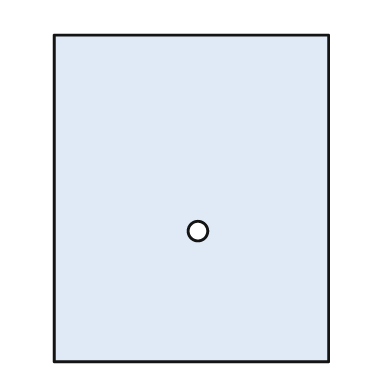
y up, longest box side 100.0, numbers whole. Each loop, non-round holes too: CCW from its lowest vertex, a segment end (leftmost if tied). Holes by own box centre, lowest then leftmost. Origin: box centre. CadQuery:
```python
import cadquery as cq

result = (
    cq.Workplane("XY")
    .moveTo(-42.0, -50.0)
    .lineTo(42.0, -50.0)
    .lineTo(42.0, 50.0)
    .lineTo(-42.0, 50.0)
    .close()
    .moveTo(2.0, -10.0)
    .circle(3.0)
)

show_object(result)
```